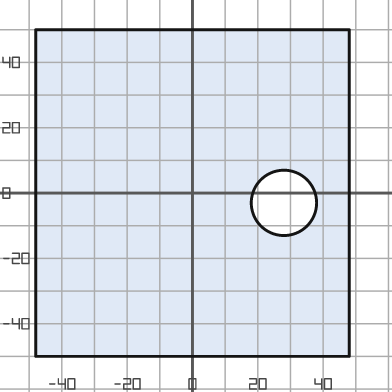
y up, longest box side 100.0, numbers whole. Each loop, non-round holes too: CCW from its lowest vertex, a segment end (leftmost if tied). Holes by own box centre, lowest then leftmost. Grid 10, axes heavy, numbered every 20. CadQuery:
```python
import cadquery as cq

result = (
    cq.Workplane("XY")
    .moveTo(-48.0, -50.0)
    .lineTo(48.0, -50.0)
    .lineTo(48.0, 50.0)
    .lineTo(-48.0, 50.0)
    .close()
    .moveTo(28.0, -3.0)
    .circle(10.0)
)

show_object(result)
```